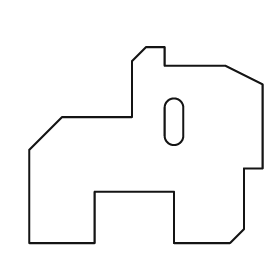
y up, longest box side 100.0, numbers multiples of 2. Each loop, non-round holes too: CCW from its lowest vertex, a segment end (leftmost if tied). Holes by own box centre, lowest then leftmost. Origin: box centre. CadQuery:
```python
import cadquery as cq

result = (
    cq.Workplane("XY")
    .moveTo(-50.0, -42.0)
    .lineTo(-22.0, -42.0)
    .lineTo(-22.0, -20.0)
    .lineTo(12.0, -20.0)
    .lineTo(12.0, -42.0)
    .lineTo(36.0, -42.0)
    .lineTo(42.0, -36.0)
    .lineTo(42.0, -10.0)
    .lineTo(50.0, -10.0)
    .lineTo(50.0, 26.0)
    .lineTo(34.0, 34.0)
    .lineTo(8.0, 34.0)
    .lineTo(8.0, 42.0)
    .lineTo(0.0, 42.0)
    .lineTo(-6.0, 36.0)
    .lineTo(-6.0, 12.0)
    .lineTo(-36.0, 12.0)
    .lineTo(-50.0, -2.0)
    .close()
    .moveTo(8.0, 4.0)
    .threePointArc((12.0, 0.0), (16.0, 4.0))
    .lineTo(16.0, 16.0)
    .threePointArc((12.0, 20.0), (8.0, 16.0))
    .close()
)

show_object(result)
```